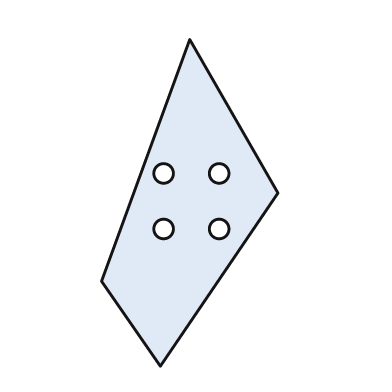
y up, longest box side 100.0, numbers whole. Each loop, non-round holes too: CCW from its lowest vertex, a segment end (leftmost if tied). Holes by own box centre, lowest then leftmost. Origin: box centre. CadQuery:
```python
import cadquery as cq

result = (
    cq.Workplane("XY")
    .moveTo(-9.0, -50.0)
    .lineTo(27.0, 3.0)
    .lineTo(0.0, 50.0)
    .lineTo(-27.0, -24.0)
    .close()
    .moveTo(-8.0, -8.0)
    .circle(3.0)
    .moveTo(9.0, -8.0)
    .circle(3.0)
    .moveTo(-8.0, 9.0)
    .circle(3.0)
    .moveTo(9.0, 9.0)
    .circle(3.0)
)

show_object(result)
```